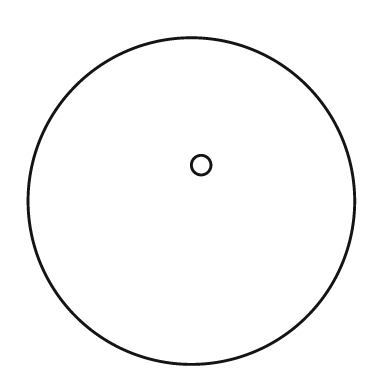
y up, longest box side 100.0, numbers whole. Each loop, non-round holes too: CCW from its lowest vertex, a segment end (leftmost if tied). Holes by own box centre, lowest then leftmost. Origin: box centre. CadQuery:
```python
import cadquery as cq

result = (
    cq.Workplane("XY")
    .moveTo(0.0, 0.0)
    .circle(50.0)
    .moveTo(3.0, 11.0)
    .circle(3.0)
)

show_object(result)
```